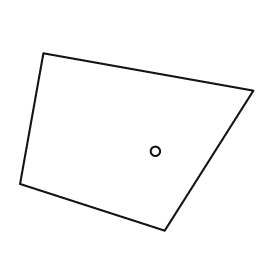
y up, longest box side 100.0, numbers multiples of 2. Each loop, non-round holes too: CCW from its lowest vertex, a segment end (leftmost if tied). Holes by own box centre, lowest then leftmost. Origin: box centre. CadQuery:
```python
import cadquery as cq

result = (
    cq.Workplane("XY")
    .moveTo(12.0, -38.0)
    .lineTo(50.0, 22.0)
    .lineTo(-40.0, 38.0)
    .lineTo(-50.0, -18.0)
    .close()
    .moveTo(8.0, -4.0)
    .circle(2.0)
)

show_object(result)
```